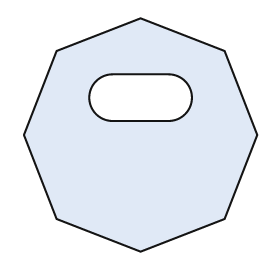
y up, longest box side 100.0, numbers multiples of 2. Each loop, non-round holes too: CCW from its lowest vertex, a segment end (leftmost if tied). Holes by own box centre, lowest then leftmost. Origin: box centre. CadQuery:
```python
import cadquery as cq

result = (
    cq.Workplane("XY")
    .moveTo(0.0, -50.0)
    .lineTo(36.0, -36.0)
    .lineTo(50.0, 0.0)
    .lineTo(36.0, 36.0)
    .lineTo(0.0, 50.0)
    .lineTo(-36.0, 36.0)
    .lineTo(-50.0, 0.0)
    .lineTo(-36.0, -36.0)
    .close()
    .moveTo(-12.0, 6.0)
    .lineTo(12.0, 6.0)
    .threePointArc((22.0, 16.0), (12.0, 26.0))
    .lineTo(-12.0, 26.0)
    .threePointArc((-22.0, 16.0), (-12.0, 6.0))
    .close()
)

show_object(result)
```